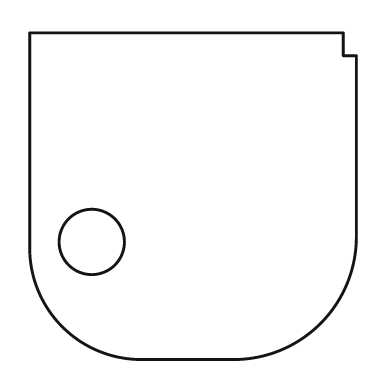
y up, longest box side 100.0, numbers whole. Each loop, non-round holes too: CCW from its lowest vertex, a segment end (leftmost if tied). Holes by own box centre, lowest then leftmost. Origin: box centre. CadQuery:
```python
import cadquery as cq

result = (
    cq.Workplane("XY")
    .moveTo(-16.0, -50.0)
    .lineTo(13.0, -50.0)
    .threePointArc((39.0, -39.0), (50.0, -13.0))
    .lineTo(50.0, 43.0)
    .lineTo(46.0, 43.0)
    .lineTo(46.0, 50.0)
    .lineTo(-50.0, 50.0)
    .lineTo(-50.0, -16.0)
    .threePointArc((-40.0, -40.0), (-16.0, -50.0))
    .close()
    .moveTo(-31.0, -14.0)
    .circle(10.0)
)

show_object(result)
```